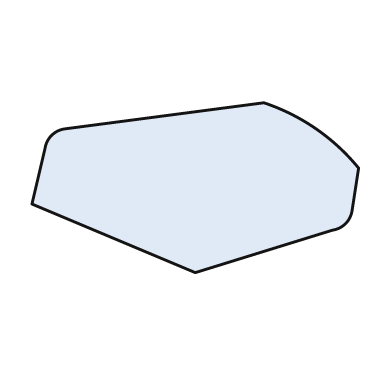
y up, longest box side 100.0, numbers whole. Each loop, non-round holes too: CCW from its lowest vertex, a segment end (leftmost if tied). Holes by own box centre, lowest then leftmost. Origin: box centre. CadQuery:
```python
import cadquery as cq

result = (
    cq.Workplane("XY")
    .moveTo(0.0, -26.0)
    .lineTo(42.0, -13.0)
    .threePointArc((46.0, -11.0), (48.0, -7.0))
    .lineTo(50.0, 6.0)
    .threePointArc((37.0, 18.0), (21.0, 26.0))
    .lineTo(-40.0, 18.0)
    .threePointArc((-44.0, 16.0), (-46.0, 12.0))
    .lineTo(-50.0, -5.0)
    .close()
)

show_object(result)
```